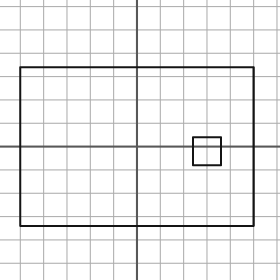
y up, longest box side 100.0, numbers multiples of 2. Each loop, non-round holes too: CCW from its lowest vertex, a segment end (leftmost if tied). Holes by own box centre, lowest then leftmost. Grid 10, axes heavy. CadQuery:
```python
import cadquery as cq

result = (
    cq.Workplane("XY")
    .moveTo(-50.0, -34.0)
    .lineTo(50.0, -34.0)
    .lineTo(50.0, 34.0)
    .lineTo(-50.0, 34.0)
    .close()
    .moveTo(24.0, -8.0)
    .lineTo(36.0, -8.0)
    .lineTo(36.0, 4.0)
    .lineTo(24.0, 4.0)
    .close()
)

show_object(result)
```